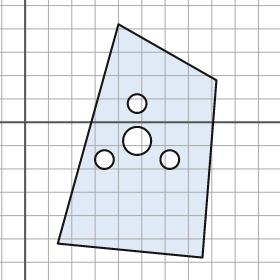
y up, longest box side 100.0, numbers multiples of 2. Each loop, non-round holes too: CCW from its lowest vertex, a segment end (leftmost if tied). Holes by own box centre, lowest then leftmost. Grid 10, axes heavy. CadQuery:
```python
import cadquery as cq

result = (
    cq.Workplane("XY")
    .moveTo(76.0, -58.0)
    .lineTo(82.0, 18.0)
    .lineTo(40.0, 42.0)
    .lineTo(14.0, -52.0)
    .close()
    .moveTo(34.0, -16.0)
    .circle(4.0)
    .moveTo(62.0, -16.0)
    .circle(4.0)
    .moveTo(48.0, -8.0)
    .circle(6.0)
    .moveTo(48.0, 8.0)
    .circle(4.0)
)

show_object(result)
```